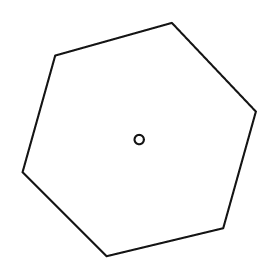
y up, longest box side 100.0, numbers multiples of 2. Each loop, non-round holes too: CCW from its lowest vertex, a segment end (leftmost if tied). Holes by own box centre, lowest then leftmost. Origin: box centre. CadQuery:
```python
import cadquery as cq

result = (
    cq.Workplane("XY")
    .moveTo(-14.0, -50.0)
    .lineTo(36.0, -38.0)
    .lineTo(50.0, 12.0)
    .lineTo(14.0, 50.0)
    .lineTo(-36.0, 36.0)
    .lineTo(-50.0, -14.0)
    .close()
    .moveTo(0.0, 0.0)
    .circle(2.0)
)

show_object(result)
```